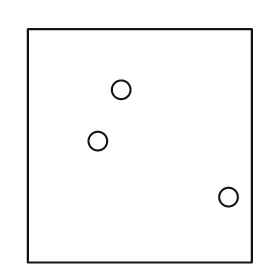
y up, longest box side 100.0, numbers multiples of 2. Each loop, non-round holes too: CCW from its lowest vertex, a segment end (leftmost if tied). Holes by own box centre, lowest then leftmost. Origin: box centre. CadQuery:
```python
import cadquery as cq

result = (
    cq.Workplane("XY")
    .moveTo(-48.0, -50.0)
    .lineTo(48.0, -50.0)
    .lineTo(48.0, 50.0)
    .lineTo(-48.0, 50.0)
    .close()
    .moveTo(38.0, -22.0)
    .circle(4.0)
    .moveTo(-18.0, 2.0)
    .circle(4.0)
    .moveTo(-8.0, 24.0)
    .circle(4.0)
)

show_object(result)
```